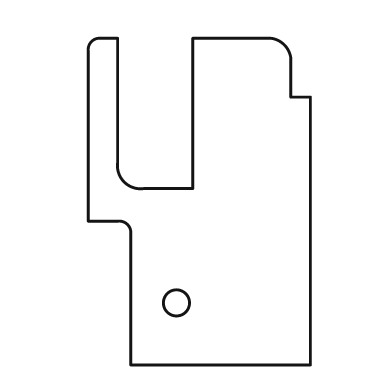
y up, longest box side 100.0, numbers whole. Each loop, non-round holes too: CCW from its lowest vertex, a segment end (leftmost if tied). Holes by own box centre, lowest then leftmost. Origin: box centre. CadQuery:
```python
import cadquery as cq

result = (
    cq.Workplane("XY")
    .moveTo(-21.0, -50.0)
    .lineTo(34.0, -50.0)
    .lineTo(34.0, 32.0)
    .lineTo(28.0, 32.0)
    .lineTo(28.0, 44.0)
    .threePointArc((26.0, 48.0), (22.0, 50.0))
    .lineTo(-2.0, 50.0)
    .lineTo(-2.0, 4.0)
    .lineTo(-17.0, 4.0)
    .threePointArc((-23.0, 6.0), (-25.0, 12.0))
    .lineTo(-25.0, 50.0)
    .lineTo(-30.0, 50.0)
    .threePointArc((-33.0, 49.0), (-34.0, 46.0))
    .lineTo(-34.0, -6.0)
    .lineTo(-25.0, -6.0)
    .threePointArc((-22.0, -7.0), (-21.0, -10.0))
    .close()
    .moveTo(-7.0, -31.0)
    .circle(4.0)
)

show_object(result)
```